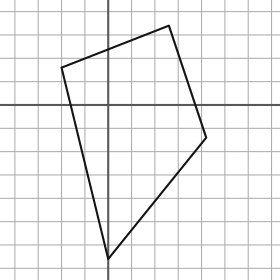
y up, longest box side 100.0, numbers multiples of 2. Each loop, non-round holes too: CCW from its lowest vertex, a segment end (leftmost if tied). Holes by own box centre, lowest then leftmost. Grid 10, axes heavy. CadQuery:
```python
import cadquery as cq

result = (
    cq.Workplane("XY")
    .moveTo(0.0, -66.0)
    .lineTo(42.0, -14.0)
    .lineTo(26.0, 34.0)
    .lineTo(-20.0, 16.0)
    .close()
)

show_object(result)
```